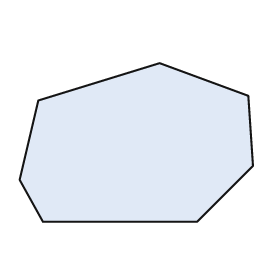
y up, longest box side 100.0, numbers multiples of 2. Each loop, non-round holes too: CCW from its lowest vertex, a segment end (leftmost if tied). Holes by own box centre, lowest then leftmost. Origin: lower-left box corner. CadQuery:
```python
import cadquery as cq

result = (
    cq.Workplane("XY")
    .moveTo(10.0, 0.0)
    .lineTo(76.0, 0.0)
    .lineTo(100.0, 24.0)
    .lineTo(98.0, 54.0)
    .lineTo(60.0, 68.0)
    .lineTo(8.0, 52.0)
    .lineTo(0.0, 18.0)
    .close()
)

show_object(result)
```